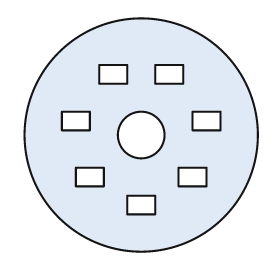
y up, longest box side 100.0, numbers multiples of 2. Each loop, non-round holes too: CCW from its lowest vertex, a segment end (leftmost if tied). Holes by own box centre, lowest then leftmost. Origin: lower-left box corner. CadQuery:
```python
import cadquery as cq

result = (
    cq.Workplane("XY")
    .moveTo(50.0, 50.0)
    .circle(50.0)
    .moveTo(44.0, 16.0)
    .lineTo(56.0, 16.0)
    .lineTo(56.0, 24.0)
    .lineTo(44.0, 24.0)
    .close()
    .moveTo(22.0, 28.0)
    .lineTo(34.0, 28.0)
    .lineTo(34.0, 36.0)
    .lineTo(22.0, 36.0)
    .close()
    .moveTo(66.0, 28.0)
    .lineTo(78.0, 28.0)
    .lineTo(78.0, 36.0)
    .lineTo(66.0, 36.0)
    .close()
    .moveTo(50.0, 50.0)
    .circle(10.0)
    .moveTo(16.0, 52.0)
    .lineTo(28.0, 52.0)
    .lineTo(28.0, 60.0)
    .lineTo(16.0, 60.0)
    .close()
    .moveTo(72.0, 52.0)
    .lineTo(84.0, 52.0)
    .lineTo(84.0, 60.0)
    .lineTo(72.0, 60.0)
    .close()
    .moveTo(32.0, 72.0)
    .lineTo(44.0, 72.0)
    .lineTo(44.0, 80.0)
    .lineTo(32.0, 80.0)
    .close()
    .moveTo(56.0, 72.0)
    .lineTo(68.0, 72.0)
    .lineTo(68.0, 80.0)
    .lineTo(56.0, 80.0)
    .close()
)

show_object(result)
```